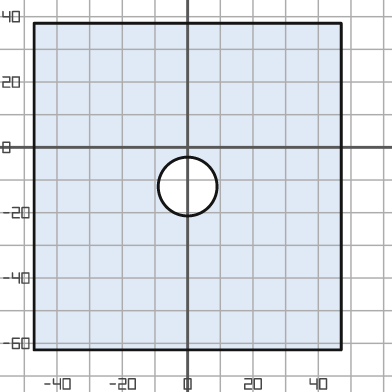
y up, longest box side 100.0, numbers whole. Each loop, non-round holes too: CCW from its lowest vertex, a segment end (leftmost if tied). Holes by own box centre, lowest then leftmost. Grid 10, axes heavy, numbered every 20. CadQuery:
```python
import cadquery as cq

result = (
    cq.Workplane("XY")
    .moveTo(-47.0, -62.0)
    .lineTo(47.0, -62.0)
    .lineTo(47.0, 38.0)
    .lineTo(-47.0, 38.0)
    .close()
    .moveTo(0.0, -12.0)
    .circle(9.0)
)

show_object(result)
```